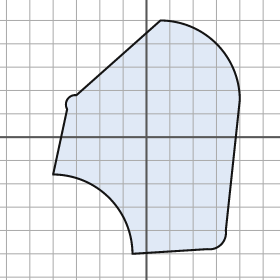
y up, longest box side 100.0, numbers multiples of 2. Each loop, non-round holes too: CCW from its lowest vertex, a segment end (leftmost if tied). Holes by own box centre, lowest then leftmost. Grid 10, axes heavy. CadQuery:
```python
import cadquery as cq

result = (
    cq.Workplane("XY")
    .moveTo(-6.0, -50.0)
    .lineTo(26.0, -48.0)
    .threePointArc((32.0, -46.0), (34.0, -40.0))
    .lineTo(40.0, 16.0)
    .threePointArc((30.0, 40.0), (6.0, 50.0))
    .lineTo(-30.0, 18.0)
    .threePointArc((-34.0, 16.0), (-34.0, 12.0))
    .lineTo(-40.0, -16.0)
    .threePointArc((-16.0, -26.0), (-6.0, -50.0))
    .close()
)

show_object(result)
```